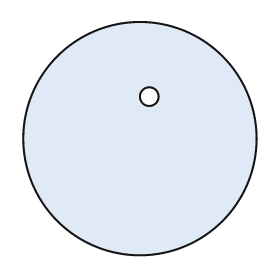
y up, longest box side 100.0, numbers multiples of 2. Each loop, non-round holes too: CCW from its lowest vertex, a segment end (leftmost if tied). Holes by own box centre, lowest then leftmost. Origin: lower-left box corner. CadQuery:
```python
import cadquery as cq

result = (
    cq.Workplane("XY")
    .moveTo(50.0, 50.0)
    .circle(50.0)
    .moveTo(54.0, 68.0)
    .circle(4.0)
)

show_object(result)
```